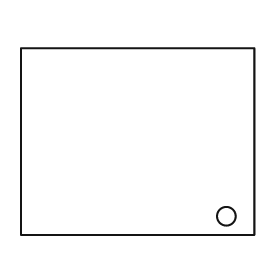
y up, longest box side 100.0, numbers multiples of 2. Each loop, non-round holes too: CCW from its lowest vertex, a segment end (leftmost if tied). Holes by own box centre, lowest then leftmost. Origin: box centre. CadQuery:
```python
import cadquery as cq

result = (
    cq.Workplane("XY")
    .moveTo(-50.0, -40.0)
    .lineTo(50.0, -40.0)
    .lineTo(50.0, 40.0)
    .lineTo(-50.0, 40.0)
    .close()
    .moveTo(38.0, -32.0)
    .circle(4.0)
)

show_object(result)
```